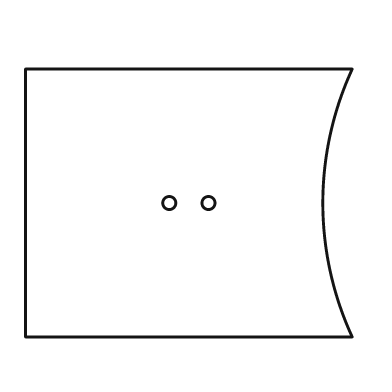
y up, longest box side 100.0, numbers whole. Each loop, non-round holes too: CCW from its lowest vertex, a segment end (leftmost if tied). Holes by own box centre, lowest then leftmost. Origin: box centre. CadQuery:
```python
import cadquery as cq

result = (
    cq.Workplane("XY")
    .moveTo(-50.0, -41.0)
    .lineTo(50.0, -41.0)
    .threePointArc((41.0, 0.0), (50.0, 41.0))
    .lineTo(-50.0, 41.0)
    .close()
    .moveTo(-6.0, 0.0)
    .circle(2.0)
    .moveTo(6.0, 0.0)
    .circle(2.0)
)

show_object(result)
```